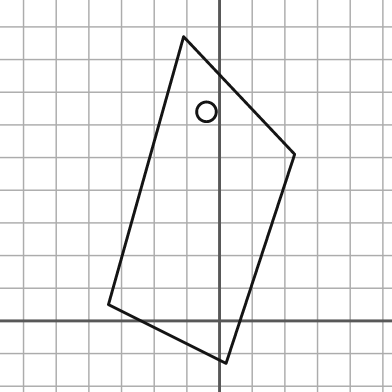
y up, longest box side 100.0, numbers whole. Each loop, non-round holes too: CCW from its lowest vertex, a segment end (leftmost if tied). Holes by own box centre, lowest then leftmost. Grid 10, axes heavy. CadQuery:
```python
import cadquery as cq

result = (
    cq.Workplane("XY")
    .moveTo(2.0, -13.0)
    .lineTo(23.0, 51.0)
    .lineTo(-11.0, 87.0)
    .lineTo(-34.0, 5.0)
    .close()
    .moveTo(-4.0, 64.0)
    .circle(3.0)
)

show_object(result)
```